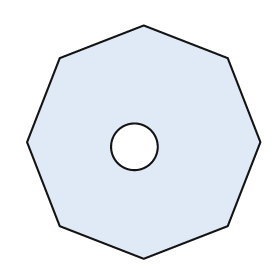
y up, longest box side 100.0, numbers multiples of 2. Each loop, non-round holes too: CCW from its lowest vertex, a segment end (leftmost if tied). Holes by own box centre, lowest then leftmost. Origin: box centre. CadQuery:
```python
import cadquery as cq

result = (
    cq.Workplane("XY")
    .moveTo(0.0, -50.0)
    .lineTo(36.0, -36.0)
    .lineTo(50.0, 0.0)
    .lineTo(36.0, 36.0)
    .lineTo(0.0, 50.0)
    .lineTo(-36.0, 36.0)
    .lineTo(-50.0, 0.0)
    .lineTo(-36.0, -36.0)
    .close()
    .moveTo(-4.0, -2.0)
    .circle(10.0)
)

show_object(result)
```